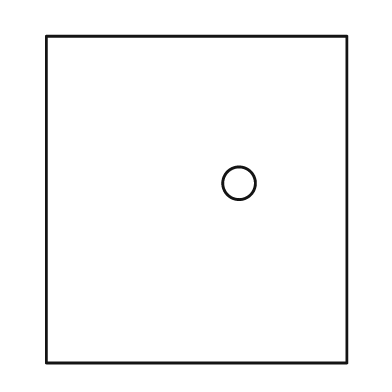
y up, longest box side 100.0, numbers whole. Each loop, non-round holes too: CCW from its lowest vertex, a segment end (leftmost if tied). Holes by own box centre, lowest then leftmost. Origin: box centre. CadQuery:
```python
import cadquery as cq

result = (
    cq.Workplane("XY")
    .moveTo(-46.0, -50.0)
    .lineTo(46.0, -50.0)
    .lineTo(46.0, 50.0)
    .lineTo(-46.0, 50.0)
    .close()
    .moveTo(13.0, 5.0)
    .circle(5.0)
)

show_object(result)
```